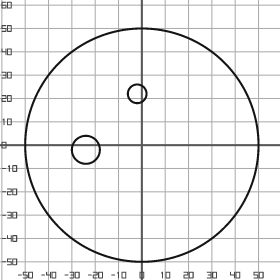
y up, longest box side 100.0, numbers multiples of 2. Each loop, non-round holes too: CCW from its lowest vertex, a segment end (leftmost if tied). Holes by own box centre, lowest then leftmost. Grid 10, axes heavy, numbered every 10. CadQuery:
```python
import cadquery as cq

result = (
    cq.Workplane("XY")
    .moveTo(0.0, 0.0)
    .circle(50.0)
    .moveTo(-24.0, -2.0)
    .circle(6.0)
    .moveTo(-2.0, 22.0)
    .circle(4.0)
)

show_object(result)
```